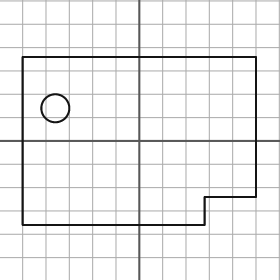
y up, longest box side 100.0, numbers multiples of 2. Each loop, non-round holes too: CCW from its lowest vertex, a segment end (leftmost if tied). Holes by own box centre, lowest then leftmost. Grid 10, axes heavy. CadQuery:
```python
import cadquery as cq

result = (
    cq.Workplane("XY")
    .moveTo(-50.0, -36.0)
    .lineTo(28.0, -36.0)
    .lineTo(28.0, -24.0)
    .lineTo(50.0, -24.0)
    .lineTo(50.0, 36.0)
    .lineTo(-50.0, 36.0)
    .close()
    .moveTo(-36.0, 14.0)
    .circle(6.0)
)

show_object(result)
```